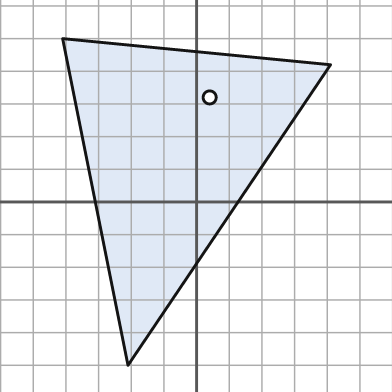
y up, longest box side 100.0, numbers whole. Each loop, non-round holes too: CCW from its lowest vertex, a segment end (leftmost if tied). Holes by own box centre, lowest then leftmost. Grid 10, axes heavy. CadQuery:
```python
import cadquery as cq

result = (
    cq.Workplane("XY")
    .moveTo(-21.0, -50.0)
    .lineTo(41.0, 42.0)
    .lineTo(-41.0, 50.0)
    .close()
    .moveTo(4.0, 32.0)
    .circle(2.0)
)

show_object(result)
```